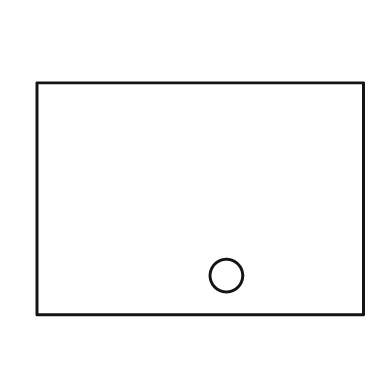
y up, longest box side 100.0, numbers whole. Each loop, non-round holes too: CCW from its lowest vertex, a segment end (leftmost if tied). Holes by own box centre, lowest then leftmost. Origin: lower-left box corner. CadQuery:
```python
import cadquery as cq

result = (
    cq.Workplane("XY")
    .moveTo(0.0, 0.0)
    .lineTo(100.0, 0.0)
    .lineTo(100.0, 71.0)
    .lineTo(0.0, 71.0)
    .close()
    .moveTo(58.0, 12.0)
    .circle(5.0)
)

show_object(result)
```